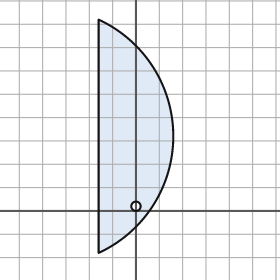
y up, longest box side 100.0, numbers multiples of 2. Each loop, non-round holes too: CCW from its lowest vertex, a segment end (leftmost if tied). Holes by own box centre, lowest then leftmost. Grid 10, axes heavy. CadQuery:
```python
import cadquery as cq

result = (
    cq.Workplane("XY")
    .moveTo(-16.0, -18.0)
    .threePointArc((16.0, 32.0), (-16.0, 82.0))
    .close()
    .moveTo(0.0, 2.0)
    .circle(2.0)
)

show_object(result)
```